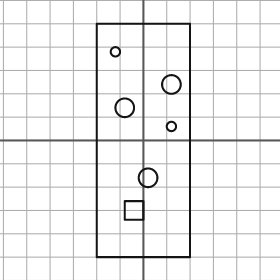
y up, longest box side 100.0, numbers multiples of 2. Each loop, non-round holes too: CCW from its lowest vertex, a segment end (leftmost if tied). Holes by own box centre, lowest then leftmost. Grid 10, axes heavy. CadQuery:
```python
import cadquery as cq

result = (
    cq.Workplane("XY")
    .moveTo(-20.0, -50.0)
    .lineTo(20.0, -50.0)
    .lineTo(20.0, 50.0)
    .lineTo(-20.0, 50.0)
    .close()
    .moveTo(-8.0, -34.0)
    .lineTo(0.0, -34.0)
    .lineTo(0.0, -26.0)
    .lineTo(-8.0, -26.0)
    .close()
    .moveTo(2.0, -16.0)
    .circle(4.0)
    .moveTo(12.0, 6.0)
    .circle(2.0)
    .moveTo(-8.0, 14.0)
    .circle(4.0)
    .moveTo(12.0, 24.0)
    .circle(4.0)
    .moveTo(-12.0, 38.0)
    .circle(2.0)
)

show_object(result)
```